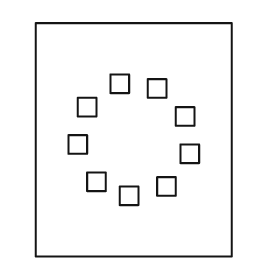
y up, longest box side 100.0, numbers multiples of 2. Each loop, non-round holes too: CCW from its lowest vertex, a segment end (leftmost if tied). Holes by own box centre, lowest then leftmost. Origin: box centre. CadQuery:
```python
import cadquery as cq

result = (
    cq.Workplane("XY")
    .moveTo(-42.0, -50.0)
    .lineTo(42.0, -50.0)
    .lineTo(42.0, 50.0)
    .lineTo(-42.0, 50.0)
    .close()
    .moveTo(-6.0, -28.0)
    .lineTo(2.0, -28.0)
    .lineTo(2.0, -20.0)
    .lineTo(-6.0, -20.0)
    .close()
    .moveTo(10.0, -24.0)
    .lineTo(18.0, -24.0)
    .lineTo(18.0, -16.0)
    .lineTo(10.0, -16.0)
    .close()
    .moveTo(-20.0, -22.0)
    .lineTo(-12.0, -22.0)
    .lineTo(-12.0, -14.0)
    .lineTo(-20.0, -14.0)
    .close()
    .moveTo(20.0, -10.0)
    .lineTo(28.0, -10.0)
    .lineTo(28.0, -2.0)
    .lineTo(20.0, -2.0)
    .close()
    .moveTo(-28.0, -6.0)
    .lineTo(-20.0, -6.0)
    .lineTo(-20.0, 2.0)
    .lineTo(-28.0, 2.0)
    .close()
    .moveTo(18.0, 6.0)
    .lineTo(26.0, 6.0)
    .lineTo(26.0, 14.0)
    .lineTo(18.0, 14.0)
    .close()
    .moveTo(-24.0, 10.0)
    .lineTo(-16.0, 10.0)
    .lineTo(-16.0, 18.0)
    .lineTo(-24.0, 18.0)
    .close()
    .moveTo(6.0, 18.0)
    .lineTo(14.0, 18.0)
    .lineTo(14.0, 26.0)
    .lineTo(6.0, 26.0)
    .close()
    .moveTo(-10.0, 20.0)
    .lineTo(-2.0, 20.0)
    .lineTo(-2.0, 28.0)
    .lineTo(-10.0, 28.0)
    .close()
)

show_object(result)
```